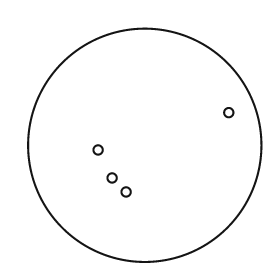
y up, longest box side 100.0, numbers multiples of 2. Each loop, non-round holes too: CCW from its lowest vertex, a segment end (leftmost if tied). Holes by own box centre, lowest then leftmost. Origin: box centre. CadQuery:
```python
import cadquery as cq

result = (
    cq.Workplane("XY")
    .moveTo(0.0, 0.0)
    .circle(50.0)
    .moveTo(-8.0, -20.0)
    .circle(2.0)
    .moveTo(-14.0, -14.0)
    .circle(2.0)
    .moveTo(-20.0, -2.0)
    .circle(2.0)
    .moveTo(36.0, 14.0)
    .circle(2.0)
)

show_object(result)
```